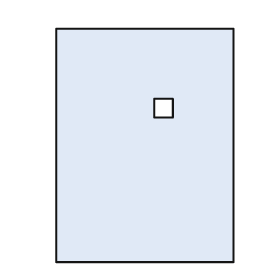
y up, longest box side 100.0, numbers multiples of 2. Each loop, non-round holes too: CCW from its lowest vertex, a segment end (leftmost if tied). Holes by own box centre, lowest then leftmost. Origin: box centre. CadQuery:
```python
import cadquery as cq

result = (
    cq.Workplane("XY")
    .moveTo(-38.0, -50.0)
    .lineTo(38.0, -50.0)
    .lineTo(38.0, 50.0)
    .lineTo(-38.0, 50.0)
    .close()
    .moveTo(4.0, 12.0)
    .lineTo(12.0, 12.0)
    .lineTo(12.0, 20.0)
    .lineTo(4.0, 20.0)
    .close()
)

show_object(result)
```